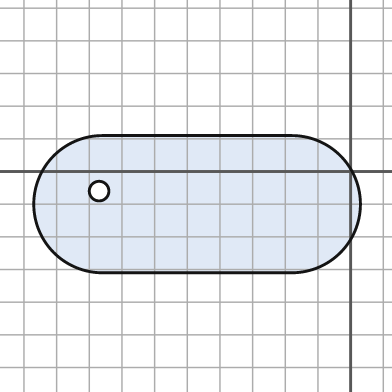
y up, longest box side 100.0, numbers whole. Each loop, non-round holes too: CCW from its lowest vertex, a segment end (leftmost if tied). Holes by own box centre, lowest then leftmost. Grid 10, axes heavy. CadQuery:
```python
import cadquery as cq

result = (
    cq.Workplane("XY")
    .moveTo(-76.0, -31.0)
    .lineTo(-18.0, -31.0)
    .threePointArc((3.0, -10.0), (-18.0, 11.0))
    .lineTo(-76.0, 11.0)
    .threePointArc((-97.0, -10.0), (-76.0, -31.0))
    .close()
    .moveTo(-77.0, -6.0)
    .circle(3.0)
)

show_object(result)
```